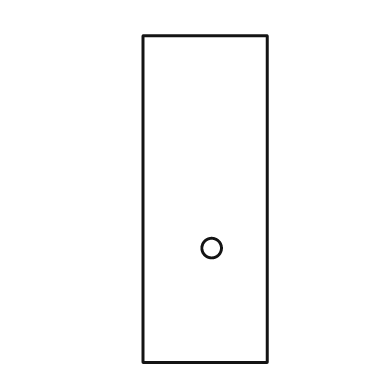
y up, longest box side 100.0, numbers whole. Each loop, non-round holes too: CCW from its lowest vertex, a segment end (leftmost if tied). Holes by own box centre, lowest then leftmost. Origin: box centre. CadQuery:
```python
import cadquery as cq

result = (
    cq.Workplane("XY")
    .moveTo(-19.0, -50.0)
    .lineTo(19.0, -50.0)
    .lineTo(19.0, 50.0)
    .lineTo(-19.0, 50.0)
    .close()
    .moveTo(2.0, -15.0)
    .circle(3.0)
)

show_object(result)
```